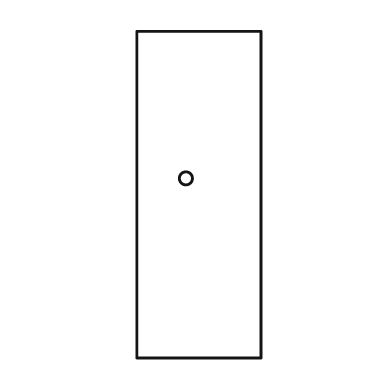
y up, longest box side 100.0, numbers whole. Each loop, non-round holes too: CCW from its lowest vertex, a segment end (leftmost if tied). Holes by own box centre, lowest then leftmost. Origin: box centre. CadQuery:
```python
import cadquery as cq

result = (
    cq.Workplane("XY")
    .moveTo(-19.0, -50.0)
    .lineTo(19.0, -50.0)
    .lineTo(19.0, 50.0)
    .lineTo(-19.0, 50.0)
    .close()
    .moveTo(-4.0, 5.0)
    .circle(2.0)
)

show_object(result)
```